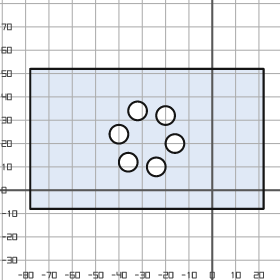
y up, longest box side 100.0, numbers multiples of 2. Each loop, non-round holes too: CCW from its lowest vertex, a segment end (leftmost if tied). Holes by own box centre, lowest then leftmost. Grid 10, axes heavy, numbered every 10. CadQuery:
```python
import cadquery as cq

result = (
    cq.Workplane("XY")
    .moveTo(-78.0, -8.0)
    .lineTo(22.0, -8.0)
    .lineTo(22.0, 52.0)
    .lineTo(-78.0, 52.0)
    .close()
    .moveTo(-24.0, 10.0)
    .circle(4.0)
    .moveTo(-36.0, 12.0)
    .circle(4.0)
    .moveTo(-16.0, 20.0)
    .circle(4.0)
    .moveTo(-40.0, 24.0)
    .circle(4.0)
    .moveTo(-20.0, 32.0)
    .circle(4.0)
    .moveTo(-32.0, 34.0)
    .circle(4.0)
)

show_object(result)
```